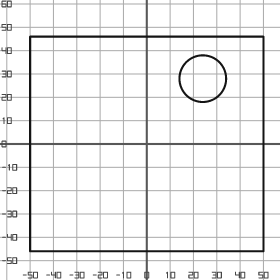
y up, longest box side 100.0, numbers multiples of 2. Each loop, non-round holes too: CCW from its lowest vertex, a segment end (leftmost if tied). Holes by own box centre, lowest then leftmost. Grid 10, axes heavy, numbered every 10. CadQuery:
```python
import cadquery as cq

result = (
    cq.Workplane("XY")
    .moveTo(-50.0, -46.0)
    .lineTo(50.0, -46.0)
    .lineTo(50.0, 46.0)
    .lineTo(-50.0, 46.0)
    .close()
    .moveTo(24.0, 28.0)
    .circle(10.0)
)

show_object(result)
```